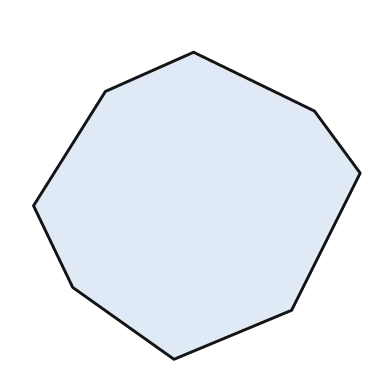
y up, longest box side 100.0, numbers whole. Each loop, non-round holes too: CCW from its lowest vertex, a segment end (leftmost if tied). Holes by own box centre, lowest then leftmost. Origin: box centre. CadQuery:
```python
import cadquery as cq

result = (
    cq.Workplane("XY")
    .moveTo(-7.0, -47.0)
    .lineTo(29.0, -32.0)
    .lineTo(50.0, 10.0)
    .lineTo(36.0, 29.0)
    .lineTo(-1.0, 47.0)
    .lineTo(-28.0, 35.0)
    .lineTo(-50.0, 0.0)
    .lineTo(-38.0, -25.0)
    .close()
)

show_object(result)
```